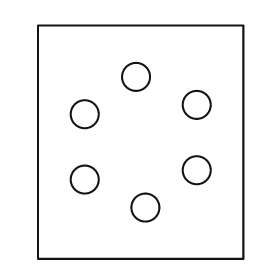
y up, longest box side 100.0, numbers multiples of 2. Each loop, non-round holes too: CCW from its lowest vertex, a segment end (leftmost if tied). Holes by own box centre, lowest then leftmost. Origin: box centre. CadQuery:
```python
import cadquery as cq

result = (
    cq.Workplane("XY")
    .moveTo(-44.0, -50.0)
    .lineTo(44.0, -50.0)
    .lineTo(44.0, 50.0)
    .lineTo(-44.0, 50.0)
    .close()
    .moveTo(2.0, -28.0)
    .circle(6.0)
    .moveTo(-24.0, -16.0)
    .circle(6.0)
    .moveTo(24.0, -12.0)
    .circle(6.0)
    .moveTo(-24.0, 12.0)
    .circle(6.0)
    .moveTo(24.0, 16.0)
    .circle(6.0)
    .moveTo(-2.0, 28.0)
    .circle(6.0)
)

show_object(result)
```